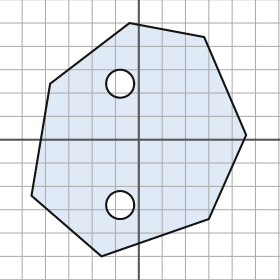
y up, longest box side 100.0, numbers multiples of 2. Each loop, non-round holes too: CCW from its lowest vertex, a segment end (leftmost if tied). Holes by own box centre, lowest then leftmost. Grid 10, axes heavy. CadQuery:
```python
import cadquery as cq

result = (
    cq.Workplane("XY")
    .moveTo(-16.0, -50.0)
    .lineTo(30.0, -34.0)
    .lineTo(46.0, 2.0)
    .lineTo(28.0, 44.0)
    .lineTo(-4.0, 50.0)
    .lineTo(-38.0, 24.0)
    .lineTo(-46.0, -24.0)
    .close()
    .moveTo(-8.0, -28.0)
    .circle(6.0)
    .moveTo(-8.0, 24.0)
    .circle(6.0)
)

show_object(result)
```